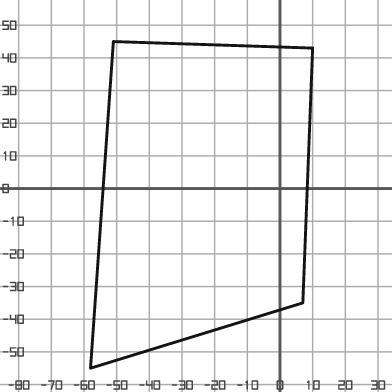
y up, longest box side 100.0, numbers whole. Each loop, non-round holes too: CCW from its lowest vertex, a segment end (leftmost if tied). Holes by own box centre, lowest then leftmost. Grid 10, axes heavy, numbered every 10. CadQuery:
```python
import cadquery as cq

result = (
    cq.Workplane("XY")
    .moveTo(-58.0, -55.0)
    .lineTo(7.0, -35.0)
    .lineTo(10.0, 43.0)
    .lineTo(-51.0, 45.0)
    .close()
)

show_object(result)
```